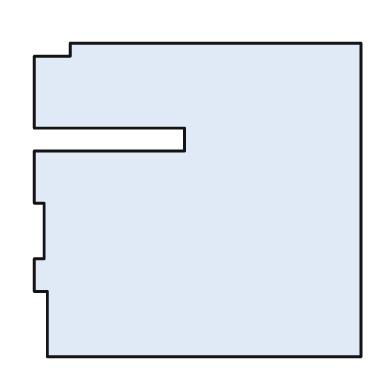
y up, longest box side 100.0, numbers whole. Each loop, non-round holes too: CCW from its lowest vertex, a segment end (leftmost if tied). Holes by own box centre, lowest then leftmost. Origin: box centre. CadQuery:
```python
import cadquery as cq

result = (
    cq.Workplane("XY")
    .moveTo(-46.0, -48.0)
    .lineTo(50.0, -48.0)
    .lineTo(50.0, 48.0)
    .lineTo(-39.0, 48.0)
    .lineTo(-39.0, 44.0)
    .lineTo(-50.0, 44.0)
    .lineTo(-50.0, 22.0)
    .lineTo(-4.0, 22.0)
    .lineTo(-4.0, 15.0)
    .lineTo(-50.0, 15.0)
    .lineTo(-50.0, -1.0)
    .lineTo(-47.0, -1.0)
    .lineTo(-47.0, -18.0)
    .lineTo(-50.0, -18.0)
    .lineTo(-50.0, -28.0)
    .lineTo(-46.0, -28.0)
    .close()
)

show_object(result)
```